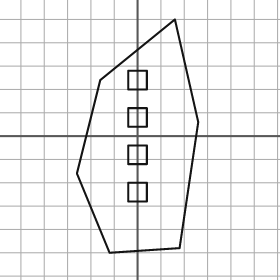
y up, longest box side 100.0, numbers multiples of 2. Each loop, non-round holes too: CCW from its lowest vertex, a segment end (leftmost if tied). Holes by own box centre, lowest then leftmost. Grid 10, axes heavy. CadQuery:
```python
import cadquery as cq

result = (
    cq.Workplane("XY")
    .moveTo(-12.0, -50.0)
    .lineTo(18.0, -48.0)
    .lineTo(26.0, 6.0)
    .lineTo(16.0, 50.0)
    .lineTo(-16.0, 24.0)
    .lineTo(-26.0, -16.0)
    .close()
    .moveTo(-4.0, -28.0)
    .lineTo(4.0, -28.0)
    .lineTo(4.0, -20.0)
    .lineTo(-4.0, -20.0)
    .close()
    .moveTo(-4.0, -12.0)
    .lineTo(4.0, -12.0)
    .lineTo(4.0, -4.0)
    .lineTo(-4.0, -4.0)
    .close()
    .moveTo(-4.0, 4.0)
    .lineTo(4.0, 4.0)
    .lineTo(4.0, 12.0)
    .lineTo(-4.0, 12.0)
    .close()
    .moveTo(-4.0, 20.0)
    .lineTo(4.0, 20.0)
    .lineTo(4.0, 28.0)
    .lineTo(-4.0, 28.0)
    .close()
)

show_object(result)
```